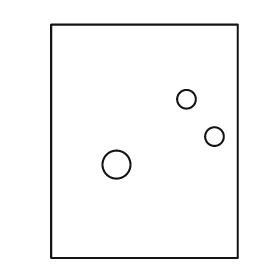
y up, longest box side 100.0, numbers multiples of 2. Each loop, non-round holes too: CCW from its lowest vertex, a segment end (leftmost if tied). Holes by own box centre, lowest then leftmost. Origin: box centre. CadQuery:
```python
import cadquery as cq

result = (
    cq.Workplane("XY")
    .moveTo(-40.0, -50.0)
    .lineTo(40.0, -50.0)
    .lineTo(40.0, 50.0)
    .lineTo(-40.0, 50.0)
    .close()
    .moveTo(-12.0, -10.0)
    .circle(6.0)
    .moveTo(30.0, 2.0)
    .circle(4.0)
    .moveTo(18.0, 18.0)
    .circle(4.0)
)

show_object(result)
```